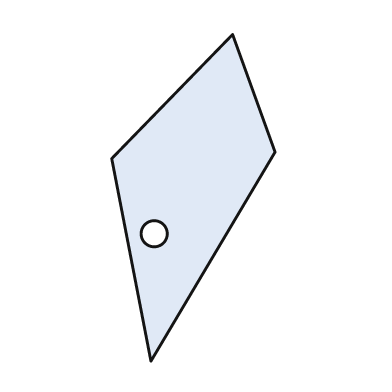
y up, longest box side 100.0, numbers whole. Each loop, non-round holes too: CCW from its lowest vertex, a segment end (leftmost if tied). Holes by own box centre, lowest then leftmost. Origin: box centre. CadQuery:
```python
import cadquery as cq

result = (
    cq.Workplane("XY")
    .moveTo(-13.0, -50.0)
    .lineTo(25.0, 14.0)
    .lineTo(12.0, 50.0)
    .lineTo(-25.0, 12.0)
    .close()
    .moveTo(-12.0, -11.0)
    .circle(4.0)
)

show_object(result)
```